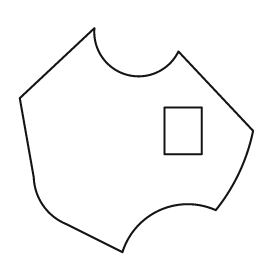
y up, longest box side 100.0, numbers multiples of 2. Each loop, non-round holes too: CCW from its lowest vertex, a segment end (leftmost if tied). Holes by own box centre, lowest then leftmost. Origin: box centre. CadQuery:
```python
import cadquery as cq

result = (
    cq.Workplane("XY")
    .moveTo(-6.0, -48.0)
    .threePointArc((10.0, -30.0), (34.0, -30.0))
    .threePointArc((44.0, -14.0), (50.0, 4.0))
    .lineTo(18.0, 38.0)
    .threePointArc((-4.0, 28.0), (-18.0, 48.0))
    .lineTo(-50.0, 18.0)
    .lineTo(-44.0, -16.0)
    .threePointArc((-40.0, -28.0), (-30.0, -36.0))
    .close()
    .moveTo(12.0, -6.0)
    .lineTo(28.0, -6.0)
    .lineTo(28.0, 14.0)
    .lineTo(12.0, 14.0)
    .close()
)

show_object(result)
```